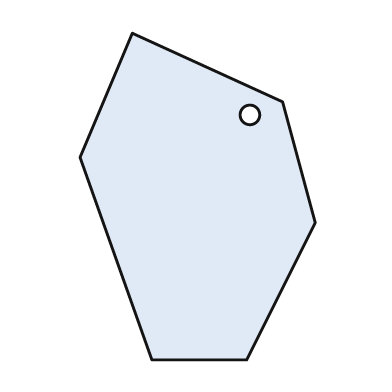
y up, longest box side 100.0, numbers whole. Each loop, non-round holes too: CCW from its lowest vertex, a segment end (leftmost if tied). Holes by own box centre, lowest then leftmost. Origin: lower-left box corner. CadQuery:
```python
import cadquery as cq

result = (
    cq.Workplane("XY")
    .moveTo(22.0, 0.0)
    .lineTo(51.0, 0.0)
    .lineTo(72.0, 42.0)
    .lineTo(62.0, 79.0)
    .lineTo(16.0, 100.0)
    .lineTo(0.0, 62.0)
    .close()
    .moveTo(52.0, 75.0)
    .circle(3.0)
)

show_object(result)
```